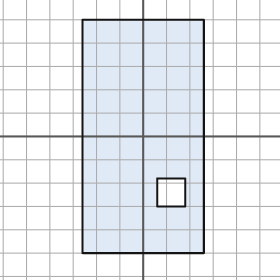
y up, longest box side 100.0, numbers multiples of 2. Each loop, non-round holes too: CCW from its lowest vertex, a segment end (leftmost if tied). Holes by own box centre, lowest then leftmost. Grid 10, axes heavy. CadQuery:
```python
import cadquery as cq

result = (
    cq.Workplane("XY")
    .moveTo(-26.0, -50.0)
    .lineTo(26.0, -50.0)
    .lineTo(26.0, 50.0)
    .lineTo(-26.0, 50.0)
    .close()
    .moveTo(6.0, -30.0)
    .lineTo(18.0, -30.0)
    .lineTo(18.0, -18.0)
    .lineTo(6.0, -18.0)
    .close()
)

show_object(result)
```